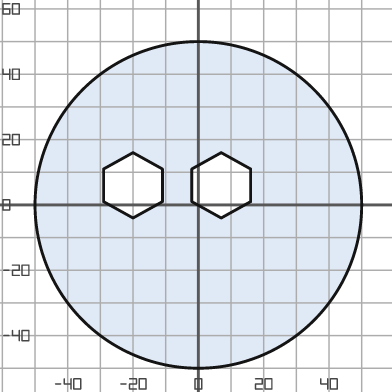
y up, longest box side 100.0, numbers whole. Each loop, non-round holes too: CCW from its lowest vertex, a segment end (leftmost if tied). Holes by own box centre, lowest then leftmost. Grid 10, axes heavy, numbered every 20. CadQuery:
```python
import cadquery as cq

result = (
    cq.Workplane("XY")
    .moveTo(0.0, 0.0)
    .circle(50.0)
    .moveTo(-20.0, -4.0)
    .lineTo(-11.0, 1.0)
    .lineTo(-11.0, 11.0)
    .lineTo(-20.0, 16.0)
    .lineTo(-29.0, 11.0)
    .lineTo(-29.0, 1.0)
    .close()
    .moveTo(7.0, -4.0)
    .lineTo(16.0, 1.0)
    .lineTo(16.0, 11.0)
    .lineTo(7.0, 16.0)
    .lineTo(-2.0, 11.0)
    .lineTo(-2.0, 1.0)
    .close()
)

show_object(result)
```